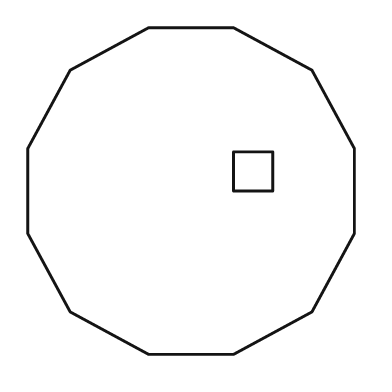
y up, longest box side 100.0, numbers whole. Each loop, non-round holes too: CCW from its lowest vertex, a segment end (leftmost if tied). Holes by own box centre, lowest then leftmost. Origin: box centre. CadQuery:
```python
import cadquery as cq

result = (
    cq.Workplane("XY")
    .moveTo(-13.0, -50.0)
    .lineTo(13.0, -50.0)
    .lineTo(37.0, -37.0)
    .lineTo(50.0, -13.0)
    .lineTo(50.0, 13.0)
    .lineTo(37.0, 37.0)
    .lineTo(13.0, 50.0)
    .lineTo(-13.0, 50.0)
    .lineTo(-37.0, 37.0)
    .lineTo(-50.0, 13.0)
    .lineTo(-50.0, -13.0)
    .lineTo(-37.0, -37.0)
    .close()
    .moveTo(13.0, 0.0)
    .lineTo(25.0, 0.0)
    .lineTo(25.0, 12.0)
    .lineTo(13.0, 12.0)
    .close()
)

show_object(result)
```